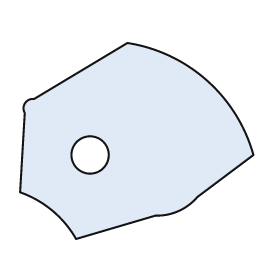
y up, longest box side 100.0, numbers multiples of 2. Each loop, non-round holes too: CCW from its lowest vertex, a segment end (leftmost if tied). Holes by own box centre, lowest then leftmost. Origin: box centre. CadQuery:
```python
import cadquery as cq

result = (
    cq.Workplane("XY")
    .moveTo(-26.0, -42.0)
    .lineTo(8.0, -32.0)
    .threePointArc((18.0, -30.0), (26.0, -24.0))
    .lineTo(50.0, -6.0)
    .threePointArc((30.0, 26.0), (-4.0, 42.0))
    .lineTo(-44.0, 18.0)
    .threePointArc((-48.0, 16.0), (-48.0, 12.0))
    .lineTo(-50.0, -22.0)
    .threePointArc((-36.0, -30.0), (-26.0, -42.0))
    .close()
    .moveTo(-20.0, -6.0)
    .circle(8.0)
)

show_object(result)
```